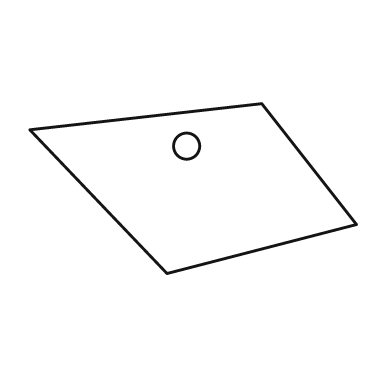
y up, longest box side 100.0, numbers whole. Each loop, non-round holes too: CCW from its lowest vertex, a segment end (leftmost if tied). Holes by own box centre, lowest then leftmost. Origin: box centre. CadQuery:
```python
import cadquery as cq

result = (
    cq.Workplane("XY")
    .moveTo(-8.0, -26.0)
    .lineTo(50.0, -11.0)
    .lineTo(21.0, 26.0)
    .lineTo(-50.0, 18.0)
    .close()
    .moveTo(-2.0, 13.0)
    .circle(4.0)
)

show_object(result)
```